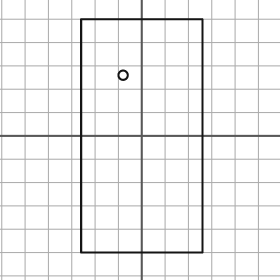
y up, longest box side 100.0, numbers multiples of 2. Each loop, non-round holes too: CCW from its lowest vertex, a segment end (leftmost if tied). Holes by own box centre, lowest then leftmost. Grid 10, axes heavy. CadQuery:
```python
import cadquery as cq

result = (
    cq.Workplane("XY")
    .moveTo(-26.0, -50.0)
    .lineTo(26.0, -50.0)
    .lineTo(26.0, 50.0)
    .lineTo(-26.0, 50.0)
    .close()
    .moveTo(-8.0, 26.0)
    .circle(2.0)
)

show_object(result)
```